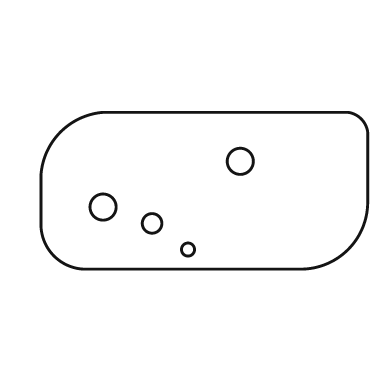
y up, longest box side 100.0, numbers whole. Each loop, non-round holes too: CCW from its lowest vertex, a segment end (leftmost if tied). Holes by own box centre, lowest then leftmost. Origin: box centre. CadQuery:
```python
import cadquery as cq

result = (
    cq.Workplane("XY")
    .moveTo(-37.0, -24.0)
    .lineTo(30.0, -24.0)
    .threePointArc((44.0, -18.0), (50.0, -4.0))
    .lineTo(50.0, 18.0)
    .threePointArc((48.0, 22.0), (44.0, 24.0))
    .lineTo(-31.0, 24.0)
    .threePointArc((-44.0, 18.0), (-50.0, 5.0))
    .lineTo(-50.0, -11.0)
    .threePointArc((-46.0, -20.0), (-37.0, -24.0))
    .close()
    .moveTo(-5.0, -18.0)
    .circle(2.0)
    .moveTo(-16.0, -10.0)
    .circle(3.0)
    .moveTo(-31.0, -5.0)
    .circle(4.0)
    .moveTo(11.0, 9.0)
    .circle(4.0)
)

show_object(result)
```